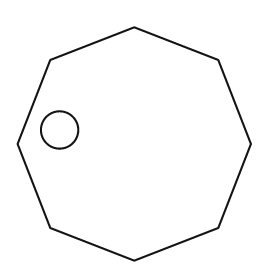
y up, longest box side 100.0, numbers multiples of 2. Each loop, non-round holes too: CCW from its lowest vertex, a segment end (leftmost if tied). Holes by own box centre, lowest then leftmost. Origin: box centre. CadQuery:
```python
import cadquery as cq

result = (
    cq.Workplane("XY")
    .moveTo(0.0, -50.0)
    .lineTo(36.0, -36.0)
    .lineTo(50.0, 0.0)
    .lineTo(36.0, 36.0)
    .lineTo(0.0, 50.0)
    .lineTo(-36.0, 36.0)
    .lineTo(-50.0, 0.0)
    .lineTo(-36.0, -36.0)
    .close()
    .moveTo(-32.0, 6.0)
    .circle(8.0)
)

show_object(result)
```